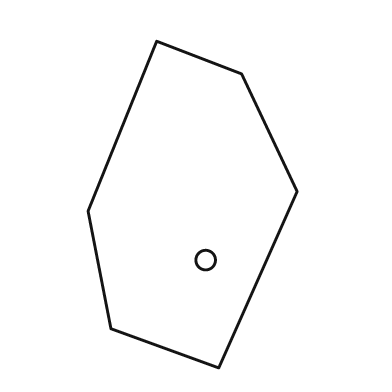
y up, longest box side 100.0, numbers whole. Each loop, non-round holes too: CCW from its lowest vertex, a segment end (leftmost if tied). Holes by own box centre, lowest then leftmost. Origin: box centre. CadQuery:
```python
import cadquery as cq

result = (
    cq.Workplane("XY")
    .moveTo(8.0, -50.0)
    .lineTo(32.0, 4.0)
    .lineTo(15.0, 40.0)
    .lineTo(-11.0, 50.0)
    .lineTo(-32.0, -2.0)
    .lineTo(-25.0, -38.0)
    .close()
    .moveTo(4.0, -17.0)
    .circle(3.0)
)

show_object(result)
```